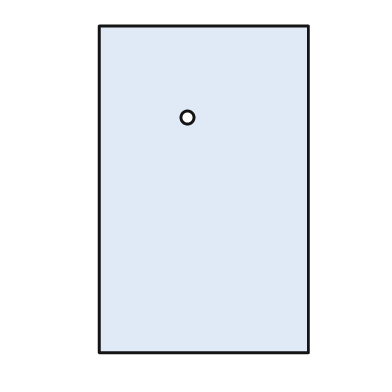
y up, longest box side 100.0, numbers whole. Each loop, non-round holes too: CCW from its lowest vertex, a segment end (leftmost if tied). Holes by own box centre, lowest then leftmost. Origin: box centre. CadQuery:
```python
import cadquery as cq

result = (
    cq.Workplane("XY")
    .moveTo(-32.0, -50.0)
    .lineTo(32.0, -50.0)
    .lineTo(32.0, 50.0)
    .lineTo(-32.0, 50.0)
    .close()
    .moveTo(-5.0, 22.0)
    .circle(2.0)
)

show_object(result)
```